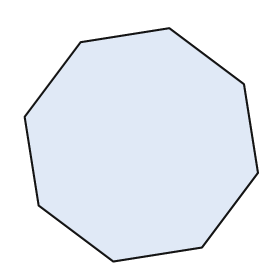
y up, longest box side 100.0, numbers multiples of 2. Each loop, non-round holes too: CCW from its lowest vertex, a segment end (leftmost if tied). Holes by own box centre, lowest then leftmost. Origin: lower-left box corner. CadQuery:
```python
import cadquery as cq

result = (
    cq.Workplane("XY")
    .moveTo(38.0, 0.0)
    .lineTo(76.0, 6.0)
    .lineTo(100.0, 38.0)
    .lineTo(94.0, 76.0)
    .lineTo(62.0, 100.0)
    .lineTo(24.0, 94.0)
    .lineTo(0.0, 62.0)
    .lineTo(6.0, 24.0)
    .close()
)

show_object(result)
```